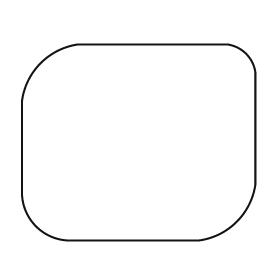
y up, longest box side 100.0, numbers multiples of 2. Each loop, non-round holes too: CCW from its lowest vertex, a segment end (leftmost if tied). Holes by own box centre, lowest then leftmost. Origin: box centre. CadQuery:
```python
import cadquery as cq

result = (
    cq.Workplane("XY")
    .moveTo(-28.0, -42.0)
    .lineTo(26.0, -42.0)
    .threePointArc((42.0, -34.0), (50.0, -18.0))
    .lineTo(50.0, 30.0)
    .threePointArc((46.0, 38.0), (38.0, 42.0))
    .lineTo(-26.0, 42.0)
    .threePointArc((-42.0, 34.0), (-50.0, 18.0))
    .lineTo(-50.0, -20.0)
    .threePointArc((-44.0, -36.0), (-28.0, -42.0))
    .close()
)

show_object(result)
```